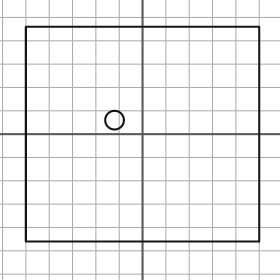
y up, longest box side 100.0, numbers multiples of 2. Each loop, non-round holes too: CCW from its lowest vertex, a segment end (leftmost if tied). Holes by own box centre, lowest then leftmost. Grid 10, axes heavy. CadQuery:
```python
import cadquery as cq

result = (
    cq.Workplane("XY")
    .moveTo(-50.0, -46.0)
    .lineTo(50.0, -46.0)
    .lineTo(50.0, 46.0)
    .lineTo(-50.0, 46.0)
    .close()
    .moveTo(-12.0, 6.0)
    .circle(4.0)
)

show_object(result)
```